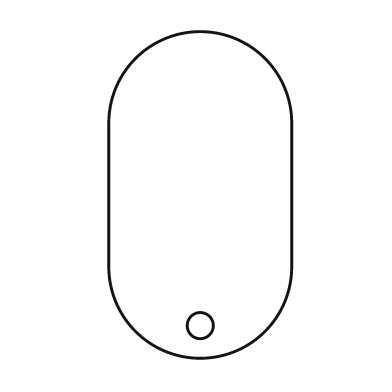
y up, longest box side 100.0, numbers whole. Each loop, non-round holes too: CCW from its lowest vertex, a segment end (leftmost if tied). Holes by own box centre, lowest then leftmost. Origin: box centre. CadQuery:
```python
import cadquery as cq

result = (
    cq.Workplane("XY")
    .moveTo(-28.0, -22.0)
    .threePointArc((0.0, -50.0), (28.0, -22.0))
    .lineTo(28.0, 22.0)
    .threePointArc((0.0, 50.0), (-28.0, 22.0))
    .close()
    .moveTo(0.0, -40.0)
    .circle(4.0)
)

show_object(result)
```